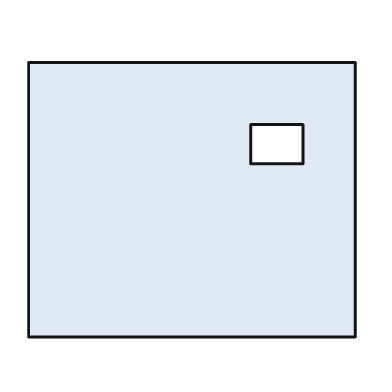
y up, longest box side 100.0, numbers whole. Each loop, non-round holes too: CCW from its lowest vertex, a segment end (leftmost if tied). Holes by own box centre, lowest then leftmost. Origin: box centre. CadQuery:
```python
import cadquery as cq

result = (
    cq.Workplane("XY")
    .moveTo(-50.0, -42.0)
    .lineTo(50.0, -42.0)
    .lineTo(50.0, 42.0)
    .lineTo(-50.0, 42.0)
    .close()
    .moveTo(18.0, 11.0)
    .lineTo(34.0, 11.0)
    .lineTo(34.0, 23.0)
    .lineTo(18.0, 23.0)
    .close()
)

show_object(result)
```